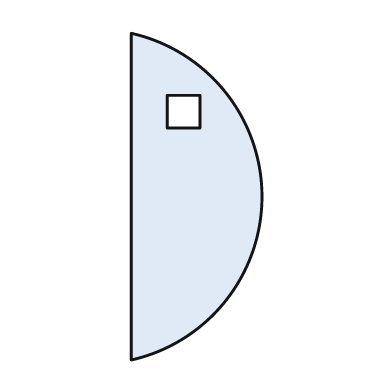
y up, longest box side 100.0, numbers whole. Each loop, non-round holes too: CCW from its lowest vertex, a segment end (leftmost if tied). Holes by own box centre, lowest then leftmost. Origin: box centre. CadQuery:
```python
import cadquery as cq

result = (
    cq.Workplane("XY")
    .moveTo(-20.0, -50.0)
    .threePointArc((20.0, 0.0), (-20.0, 50.0))
    .close()
    .moveTo(-9.0, 21.0)
    .lineTo(1.0, 21.0)
    .lineTo(1.0, 31.0)
    .lineTo(-9.0, 31.0)
    .close()
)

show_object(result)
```